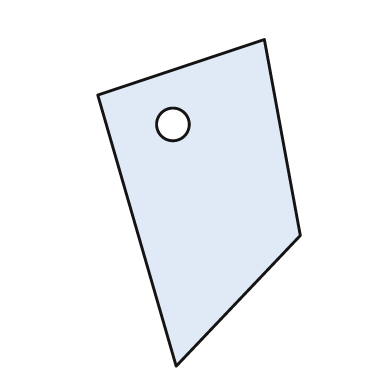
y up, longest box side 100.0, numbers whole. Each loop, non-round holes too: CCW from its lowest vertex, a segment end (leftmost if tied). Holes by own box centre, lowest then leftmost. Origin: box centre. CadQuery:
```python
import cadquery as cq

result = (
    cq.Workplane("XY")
    .moveTo(-7.0, -50.0)
    .lineTo(31.0, -10.0)
    .lineTo(20.0, 50.0)
    .lineTo(-31.0, 33.0)
    .close()
    .moveTo(-8.0, 24.0)
    .circle(5.0)
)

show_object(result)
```